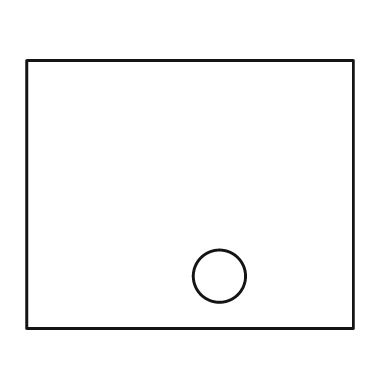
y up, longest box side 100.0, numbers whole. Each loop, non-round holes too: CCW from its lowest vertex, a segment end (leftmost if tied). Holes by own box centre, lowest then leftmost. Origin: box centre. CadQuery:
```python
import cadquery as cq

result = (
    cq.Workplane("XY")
    .moveTo(-50.0, -41.0)
    .lineTo(50.0, -41.0)
    .lineTo(50.0, 41.0)
    .lineTo(-50.0, 41.0)
    .close()
    .moveTo(9.0, -25.0)
    .circle(8.0)
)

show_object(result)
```